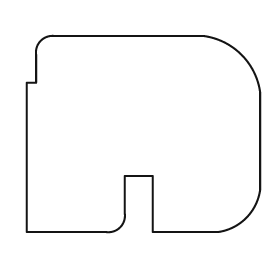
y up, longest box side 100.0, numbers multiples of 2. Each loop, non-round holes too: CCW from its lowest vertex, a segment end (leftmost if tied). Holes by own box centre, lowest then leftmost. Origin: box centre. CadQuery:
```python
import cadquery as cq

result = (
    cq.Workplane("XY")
    .moveTo(-50.0, -42.0)
    .lineTo(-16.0, -42.0)
    .threePointArc((-10.0, -40.0), (-8.0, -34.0))
    .lineTo(-8.0, -18.0)
    .lineTo(4.0, -18.0)
    .lineTo(4.0, -42.0)
    .lineTo(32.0, -42.0)
    .threePointArc((44.0, -36.0), (50.0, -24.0))
    .lineTo(50.0, 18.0)
    .threePointArc((42.0, 34.0), (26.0, 42.0))
    .lineTo(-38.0, 42.0)
    .threePointArc((-44.0, 40.0), (-46.0, 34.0))
    .lineTo(-46.0, 22.0)
    .lineTo(-50.0, 22.0)
    .close()
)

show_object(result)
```